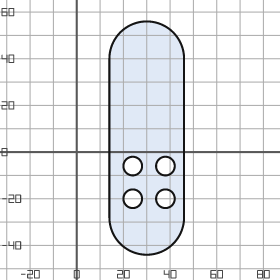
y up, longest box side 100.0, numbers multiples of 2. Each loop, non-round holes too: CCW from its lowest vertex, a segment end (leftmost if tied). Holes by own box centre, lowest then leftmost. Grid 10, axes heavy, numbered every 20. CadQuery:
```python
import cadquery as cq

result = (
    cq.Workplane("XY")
    .moveTo(14.0, -28.0)
    .threePointArc((30.0, -44.0), (46.0, -28.0))
    .lineTo(46.0, 40.0)
    .threePointArc((30.0, 56.0), (14.0, 40.0))
    .close()
    .moveTo(24.0, -20.0)
    .circle(4.0)
    .moveTo(38.0, -20.0)
    .circle(4.0)
    .moveTo(24.0, -6.0)
    .circle(4.0)
    .moveTo(38.0, -6.0)
    .circle(4.0)
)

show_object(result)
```